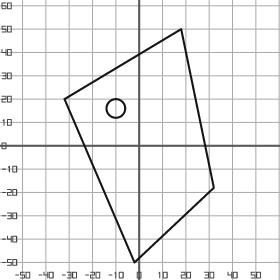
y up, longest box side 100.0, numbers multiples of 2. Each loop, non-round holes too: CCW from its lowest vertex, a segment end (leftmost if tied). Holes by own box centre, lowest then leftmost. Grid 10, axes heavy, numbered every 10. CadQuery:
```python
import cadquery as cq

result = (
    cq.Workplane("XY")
    .moveTo(-2.0, -50.0)
    .lineTo(32.0, -18.0)
    .lineTo(18.0, 50.0)
    .lineTo(-32.0, 20.0)
    .close()
    .moveTo(-10.0, 16.0)
    .circle(4.0)
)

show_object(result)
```